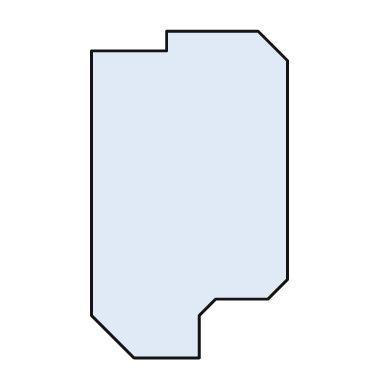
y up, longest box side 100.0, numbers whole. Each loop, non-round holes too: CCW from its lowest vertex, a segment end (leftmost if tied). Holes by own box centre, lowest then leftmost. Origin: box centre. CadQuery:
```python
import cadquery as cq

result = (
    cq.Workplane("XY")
    .moveTo(-17.0, -50.0)
    .lineTo(3.0, -50.0)
    .lineTo(3.0, -37.0)
    .lineTo(8.0, -32.0)
    .lineTo(24.0, -32.0)
    .lineTo(30.0, -26.0)
    .lineTo(30.0, 41.0)
    .lineTo(21.0, 50.0)
    .lineTo(-7.0, 50.0)
    .lineTo(-7.0, 44.0)
    .lineTo(-30.0, 44.0)
    .lineTo(-30.0, -37.0)
    .close()
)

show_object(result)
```